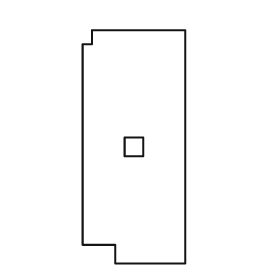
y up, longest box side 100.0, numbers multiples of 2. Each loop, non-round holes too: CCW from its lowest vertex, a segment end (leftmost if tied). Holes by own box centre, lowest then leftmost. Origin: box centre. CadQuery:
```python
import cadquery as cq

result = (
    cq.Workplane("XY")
    .moveTo(-8.0, -50.0)
    .lineTo(22.0, -50.0)
    .lineTo(22.0, 50.0)
    .lineTo(-18.0, 50.0)
    .lineTo(-18.0, 44.0)
    .lineTo(-22.0, 44.0)
    .lineTo(-22.0, -42.0)
    .lineTo(-8.0, -42.0)
    .close()
    .moveTo(-4.0, -4.0)
    .lineTo(4.0, -4.0)
    .lineTo(4.0, 4.0)
    .lineTo(-4.0, 4.0)
    .close()
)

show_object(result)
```